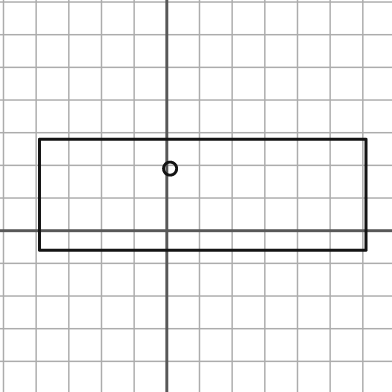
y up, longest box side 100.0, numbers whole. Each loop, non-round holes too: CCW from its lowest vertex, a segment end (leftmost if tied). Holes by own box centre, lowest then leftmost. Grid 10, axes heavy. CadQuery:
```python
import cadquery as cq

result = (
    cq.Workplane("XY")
    .moveTo(-39.0, -6.0)
    .lineTo(61.0, -6.0)
    .lineTo(61.0, 28.0)
    .lineTo(-39.0, 28.0)
    .close()
    .moveTo(1.0, 19.0)
    .circle(2.0)
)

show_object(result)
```